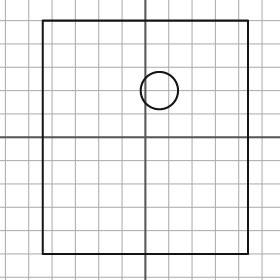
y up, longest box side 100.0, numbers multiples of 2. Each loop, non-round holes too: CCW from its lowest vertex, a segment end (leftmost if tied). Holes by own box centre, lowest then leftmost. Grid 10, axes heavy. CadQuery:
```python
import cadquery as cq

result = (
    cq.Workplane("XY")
    .moveTo(-44.0, -50.0)
    .lineTo(44.0, -50.0)
    .lineTo(44.0, 50.0)
    .lineTo(-44.0, 50.0)
    .close()
    .moveTo(6.0, 20.0)
    .circle(8.0)
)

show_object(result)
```